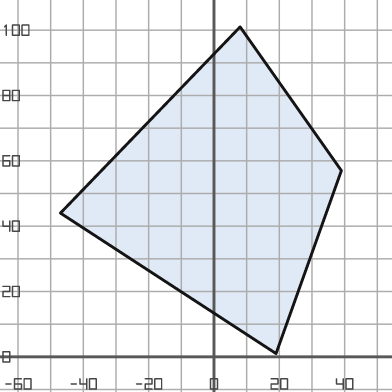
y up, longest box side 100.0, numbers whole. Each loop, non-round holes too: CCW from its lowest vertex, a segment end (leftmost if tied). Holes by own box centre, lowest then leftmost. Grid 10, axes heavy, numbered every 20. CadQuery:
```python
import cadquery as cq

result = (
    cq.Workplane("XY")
    .moveTo(19.0, 1.0)
    .lineTo(39.0, 57.0)
    .lineTo(8.0, 101.0)
    .lineTo(-47.0, 44.0)
    .close()
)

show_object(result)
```